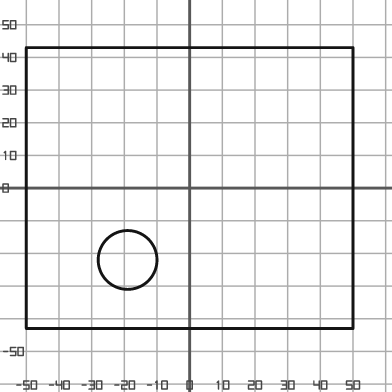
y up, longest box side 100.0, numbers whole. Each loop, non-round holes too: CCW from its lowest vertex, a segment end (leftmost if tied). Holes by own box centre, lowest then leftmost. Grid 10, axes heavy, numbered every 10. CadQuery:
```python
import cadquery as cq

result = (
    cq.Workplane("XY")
    .moveTo(-50.0, -43.0)
    .lineTo(50.0, -43.0)
    .lineTo(50.0, 43.0)
    .lineTo(-50.0, 43.0)
    .close()
    .moveTo(-19.0, -22.0)
    .circle(9.0)
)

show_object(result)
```